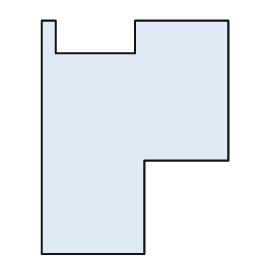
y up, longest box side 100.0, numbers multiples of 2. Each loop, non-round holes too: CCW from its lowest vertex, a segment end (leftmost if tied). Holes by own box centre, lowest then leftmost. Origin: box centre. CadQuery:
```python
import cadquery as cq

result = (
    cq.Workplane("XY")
    .moveTo(-40.0, -50.0)
    .lineTo(4.0, -50.0)
    .lineTo(4.0, -10.0)
    .lineTo(40.0, -10.0)
    .lineTo(40.0, 50.0)
    .lineTo(0.0, 50.0)
    .lineTo(0.0, 36.0)
    .lineTo(-34.0, 36.0)
    .lineTo(-34.0, 50.0)
    .lineTo(-40.0, 50.0)
    .close()
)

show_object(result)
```